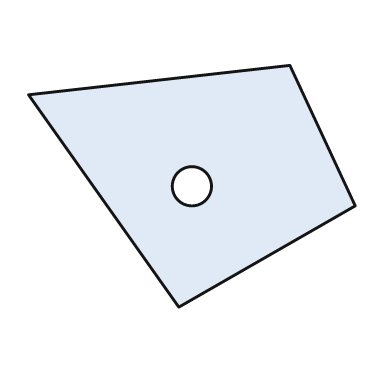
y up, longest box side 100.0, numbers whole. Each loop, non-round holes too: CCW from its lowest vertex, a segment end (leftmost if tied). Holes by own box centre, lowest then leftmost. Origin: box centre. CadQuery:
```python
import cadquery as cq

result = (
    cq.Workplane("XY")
    .moveTo(-4.0, -37.0)
    .lineTo(50.0, -6.0)
    .lineTo(30.0, 37.0)
    .lineTo(-50.0, 28.0)
    .close()
    .moveTo(0.0, 0.0)
    .circle(6.0)
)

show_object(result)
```